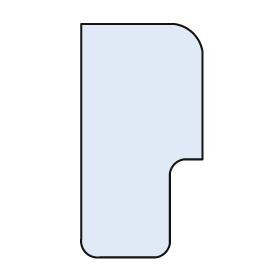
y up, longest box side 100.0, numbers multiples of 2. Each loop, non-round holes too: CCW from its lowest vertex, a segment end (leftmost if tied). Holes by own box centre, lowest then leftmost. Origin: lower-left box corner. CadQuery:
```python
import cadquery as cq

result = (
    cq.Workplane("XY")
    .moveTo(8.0, 0.0)
    .lineTo(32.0, 0.0)
    .threePointArc((36.0, 2.0), (38.0, 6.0))
    .lineTo(38.0, 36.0)
    .threePointArc((40.0, 40.0), (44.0, 42.0))
    .lineTo(52.0, 42.0)
    .lineTo(52.0, 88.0)
    .threePointArc((48.0, 96.0), (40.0, 100.0))
    .lineTo(0.0, 100.0)
    .lineTo(0.0, 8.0)
    .threePointArc((2.0, 2.0), (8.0, 0.0))
    .close()
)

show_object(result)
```